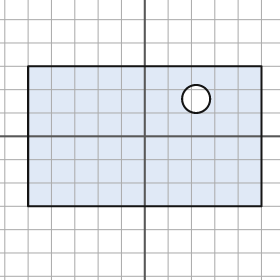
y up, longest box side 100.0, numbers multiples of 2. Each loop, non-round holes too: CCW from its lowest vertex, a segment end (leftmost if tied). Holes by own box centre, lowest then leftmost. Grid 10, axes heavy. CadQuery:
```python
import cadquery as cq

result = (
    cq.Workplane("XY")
    .moveTo(-50.0, -30.0)
    .lineTo(50.0, -30.0)
    .lineTo(50.0, 30.0)
    .lineTo(-50.0, 30.0)
    .close()
    .moveTo(22.0, 16.0)
    .circle(6.0)
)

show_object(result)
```